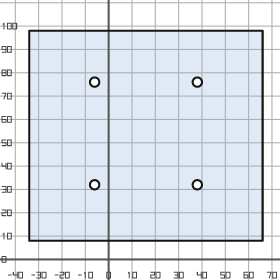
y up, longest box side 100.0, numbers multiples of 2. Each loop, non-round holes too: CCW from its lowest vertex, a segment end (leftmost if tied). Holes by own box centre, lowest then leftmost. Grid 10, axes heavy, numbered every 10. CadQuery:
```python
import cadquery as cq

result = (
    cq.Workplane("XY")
    .moveTo(-34.0, 8.0)
    .lineTo(66.0, 8.0)
    .lineTo(66.0, 98.0)
    .lineTo(-34.0, 98.0)
    .close()
    .moveTo(-6.0, 32.0)
    .circle(2.0)
    .moveTo(38.0, 32.0)
    .circle(2.0)
    .moveTo(-6.0, 76.0)
    .circle(2.0)
    .moveTo(38.0, 76.0)
    .circle(2.0)
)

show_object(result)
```